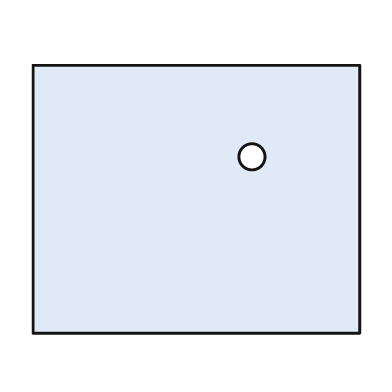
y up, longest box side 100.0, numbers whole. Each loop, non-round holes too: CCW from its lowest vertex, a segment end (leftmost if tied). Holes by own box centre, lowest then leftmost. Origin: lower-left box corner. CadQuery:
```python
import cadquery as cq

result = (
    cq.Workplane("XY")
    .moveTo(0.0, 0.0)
    .lineTo(100.0, 0.0)
    .lineTo(100.0, 82.0)
    .lineTo(0.0, 82.0)
    .close()
    .moveTo(67.0, 54.0)
    .circle(4.0)
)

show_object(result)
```